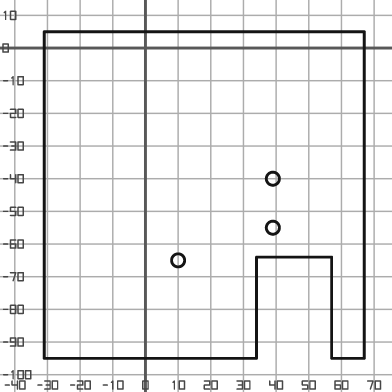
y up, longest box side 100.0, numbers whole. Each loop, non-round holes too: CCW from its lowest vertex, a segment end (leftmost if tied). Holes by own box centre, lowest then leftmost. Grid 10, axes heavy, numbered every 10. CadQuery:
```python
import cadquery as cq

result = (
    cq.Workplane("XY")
    .moveTo(-31.0, -95.0)
    .lineTo(34.0, -95.0)
    .lineTo(34.0, -64.0)
    .lineTo(57.0, -64.0)
    .lineTo(57.0, -95.0)
    .lineTo(67.0, -95.0)
    .lineTo(67.0, 5.0)
    .lineTo(-31.0, 5.0)
    .close()
    .moveTo(10.0, -65.0)
    .circle(2.0)
    .moveTo(39.0, -55.0)
    .circle(2.0)
    .moveTo(39.0, -40.0)
    .circle(2.0)
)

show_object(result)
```